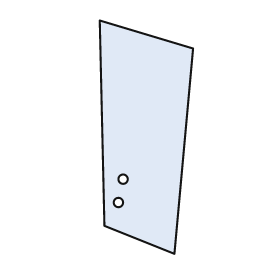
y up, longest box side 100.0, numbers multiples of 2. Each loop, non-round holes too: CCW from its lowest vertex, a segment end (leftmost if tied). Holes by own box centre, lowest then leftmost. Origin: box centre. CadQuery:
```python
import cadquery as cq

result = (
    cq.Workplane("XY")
    .moveTo(12.0, -50.0)
    .lineTo(20.0, 38.0)
    .lineTo(-20.0, 50.0)
    .lineTo(-18.0, -38.0)
    .close()
    .moveTo(-12.0, -28.0)
    .circle(2.0)
    .moveTo(-10.0, -18.0)
    .circle(2.0)
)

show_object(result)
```